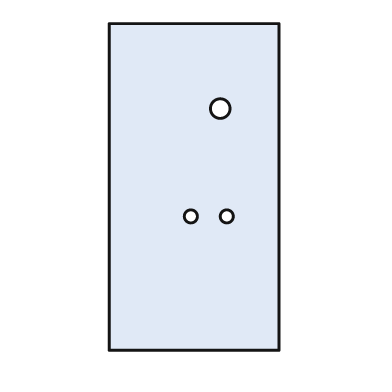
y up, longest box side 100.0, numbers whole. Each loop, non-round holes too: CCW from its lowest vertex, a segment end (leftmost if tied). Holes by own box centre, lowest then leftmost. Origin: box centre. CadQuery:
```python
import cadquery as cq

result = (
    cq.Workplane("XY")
    .moveTo(-26.0, -50.0)
    .lineTo(26.0, -50.0)
    .lineTo(26.0, 50.0)
    .lineTo(-26.0, 50.0)
    .close()
    .moveTo(-1.0, -9.0)
    .circle(2.0)
    .moveTo(10.0, -9.0)
    .circle(2.0)
    .moveTo(8.0, 24.0)
    .circle(3.0)
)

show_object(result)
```